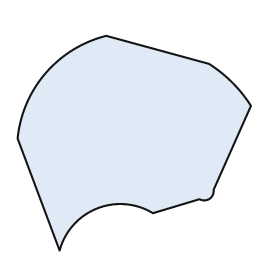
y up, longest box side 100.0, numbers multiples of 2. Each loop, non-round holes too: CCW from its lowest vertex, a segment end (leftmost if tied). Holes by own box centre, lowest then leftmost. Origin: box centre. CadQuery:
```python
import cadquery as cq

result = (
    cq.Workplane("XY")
    .moveTo(-32.0, -46.0)
    .threePointArc((-16.0, -28.0), (8.0, -30.0))
    .lineTo(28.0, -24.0)
    .threePointArc((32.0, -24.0), (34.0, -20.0))
    .lineTo(50.0, 16.0)
    .threePointArc((42.0, 26.0), (32.0, 34.0))
    .lineTo(-12.0, 46.0)
    .threePointArc((-38.0, 30.0), (-50.0, 2.0))
    .close()
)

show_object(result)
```